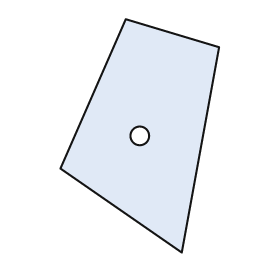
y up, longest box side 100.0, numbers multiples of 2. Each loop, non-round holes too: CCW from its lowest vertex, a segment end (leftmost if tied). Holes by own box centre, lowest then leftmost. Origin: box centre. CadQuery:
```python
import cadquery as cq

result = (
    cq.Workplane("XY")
    .moveTo(18.0, -50.0)
    .lineTo(34.0, 38.0)
    .lineTo(-6.0, 50.0)
    .lineTo(-34.0, -14.0)
    .close()
    .moveTo(0.0, 0.0)
    .circle(4.0)
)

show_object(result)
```